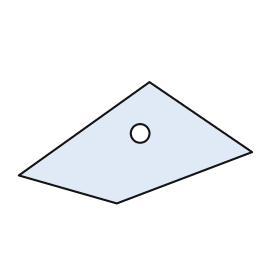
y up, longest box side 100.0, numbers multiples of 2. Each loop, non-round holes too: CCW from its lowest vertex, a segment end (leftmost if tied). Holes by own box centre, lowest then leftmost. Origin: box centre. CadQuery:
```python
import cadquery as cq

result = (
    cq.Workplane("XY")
    .moveTo(-8.0, -26.0)
    .lineTo(50.0, -4.0)
    .lineTo(6.0, 26.0)
    .lineTo(-50.0, -14.0)
    .close()
    .moveTo(2.0, 4.0)
    .circle(4.0)
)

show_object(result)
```